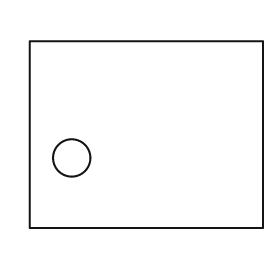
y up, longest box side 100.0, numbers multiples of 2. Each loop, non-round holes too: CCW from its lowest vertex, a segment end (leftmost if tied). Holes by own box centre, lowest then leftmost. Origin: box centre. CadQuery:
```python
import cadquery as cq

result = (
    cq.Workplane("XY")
    .moveTo(-50.0, -40.0)
    .lineTo(50.0, -40.0)
    .lineTo(50.0, 40.0)
    .lineTo(-50.0, 40.0)
    .close()
    .moveTo(-32.0, -10.0)
    .circle(8.0)
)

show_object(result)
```